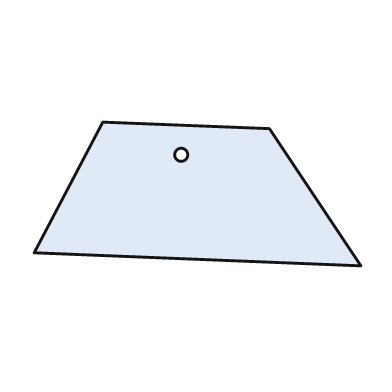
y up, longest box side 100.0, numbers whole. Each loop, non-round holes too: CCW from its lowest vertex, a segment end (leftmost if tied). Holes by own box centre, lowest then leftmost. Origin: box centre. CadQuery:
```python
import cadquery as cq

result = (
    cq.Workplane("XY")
    .moveTo(50.0, -22.0)
    .lineTo(22.0, 20.0)
    .lineTo(-29.0, 22.0)
    .lineTo(-50.0, -18.0)
    .close()
    .moveTo(-5.0, 12.0)
    .circle(2.0)
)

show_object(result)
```